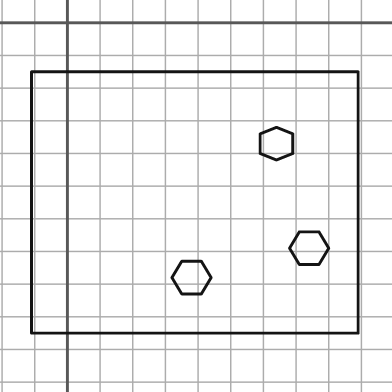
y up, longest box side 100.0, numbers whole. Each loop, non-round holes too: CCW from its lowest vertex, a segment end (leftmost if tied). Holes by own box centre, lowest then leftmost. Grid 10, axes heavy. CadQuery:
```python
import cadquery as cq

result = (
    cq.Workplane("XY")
    .moveTo(-11.0, -95.0)
    .lineTo(89.0, -95.0)
    .lineTo(89.0, -15.0)
    .lineTo(-11.0, -15.0)
    .close()
    .moveTo(35.0, -83.0)
    .lineTo(41.0, -83.0)
    .lineTo(44.0, -78.0)
    .lineTo(41.0, -73.0)
    .lineTo(35.0, -73.0)
    .lineTo(32.0, -78.0)
    .close()
    .moveTo(71.0, -74.0)
    .lineTo(77.0, -74.0)
    .lineTo(80.0, -69.0)
    .lineTo(77.0, -64.0)
    .lineTo(71.0, -64.0)
    .lineTo(68.0, -69.0)
    .close()
    .moveTo(64.0, -42.0)
    .lineTo(69.0, -40.0)
    .lineTo(69.0, -34.0)
    .lineTo(64.0, -32.0)
    .lineTo(59.0, -34.0)
    .lineTo(59.0, -40.0)
    .close()
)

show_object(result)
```